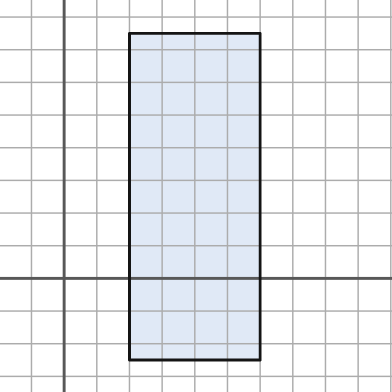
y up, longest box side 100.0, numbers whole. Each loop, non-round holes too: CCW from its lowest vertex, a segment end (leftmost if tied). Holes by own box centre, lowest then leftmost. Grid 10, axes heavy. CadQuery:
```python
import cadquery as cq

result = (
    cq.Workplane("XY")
    .moveTo(20.0, -25.0)
    .lineTo(60.0, -25.0)
    .lineTo(60.0, 75.0)
    .lineTo(20.0, 75.0)
    .close()
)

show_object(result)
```